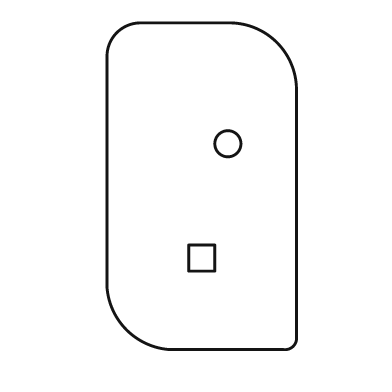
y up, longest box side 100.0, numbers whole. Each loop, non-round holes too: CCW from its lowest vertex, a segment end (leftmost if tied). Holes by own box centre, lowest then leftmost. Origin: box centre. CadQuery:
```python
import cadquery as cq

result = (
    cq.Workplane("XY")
    .moveTo(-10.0, -50.0)
    .lineTo(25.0, -50.0)
    .threePointArc((28.0, -49.0), (29.0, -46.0))
    .lineTo(29.0, 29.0)
    .threePointArc((23.0, 44.0), (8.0, 50.0))
    .lineTo(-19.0, 50.0)
    .threePointArc((-26.0, 47.0), (-29.0, 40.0))
    .lineTo(-29.0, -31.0)
    .threePointArc((-23.0, -44.0), (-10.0, -50.0))
    .close()
    .moveTo(-4.0, -26.0)
    .lineTo(4.0, -26.0)
    .lineTo(4.0, -18.0)
    .lineTo(-4.0, -18.0)
    .close()
    .moveTo(8.0, 13.0)
    .circle(4.0)
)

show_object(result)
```